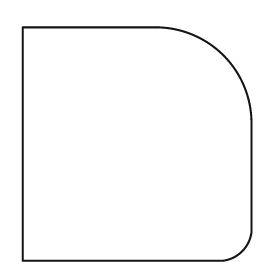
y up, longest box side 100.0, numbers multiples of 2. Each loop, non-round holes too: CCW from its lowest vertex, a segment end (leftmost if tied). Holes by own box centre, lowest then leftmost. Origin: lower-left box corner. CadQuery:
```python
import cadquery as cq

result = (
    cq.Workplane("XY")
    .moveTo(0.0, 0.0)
    .lineTo(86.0, 0.0)
    .threePointArc((94.0, 4.0), (98.0, 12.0))
    .lineTo(98.0, 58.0)
    .threePointArc((86.0, 88.0), (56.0, 100.0))
    .lineTo(0.0, 100.0)
    .close()
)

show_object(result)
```